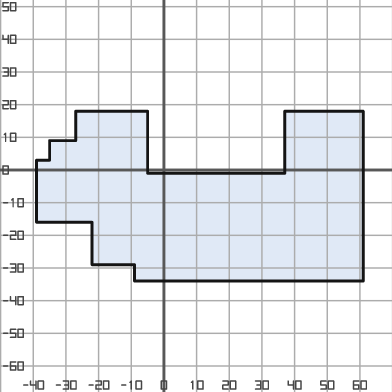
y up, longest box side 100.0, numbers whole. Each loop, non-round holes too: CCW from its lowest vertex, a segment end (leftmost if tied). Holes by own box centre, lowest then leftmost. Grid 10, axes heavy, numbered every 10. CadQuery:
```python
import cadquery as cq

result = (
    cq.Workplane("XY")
    .moveTo(-9.0, -34.0)
    .lineTo(61.0, -34.0)
    .lineTo(61.0, 18.0)
    .lineTo(37.0, 18.0)
    .lineTo(37.0, -1.0)
    .lineTo(-5.0, -1.0)
    .lineTo(-5.0, 18.0)
    .lineTo(-27.0, 18.0)
    .lineTo(-27.0, 9.0)
    .lineTo(-35.0, 9.0)
    .lineTo(-35.0, 3.0)
    .lineTo(-39.0, 3.0)
    .lineTo(-39.0, -16.0)
    .lineTo(-22.0, -16.0)
    .lineTo(-22.0, -29.0)
    .lineTo(-9.0, -29.0)
    .close()
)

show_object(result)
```